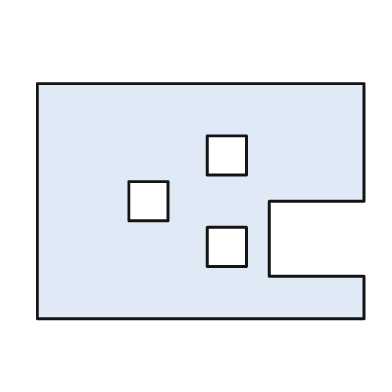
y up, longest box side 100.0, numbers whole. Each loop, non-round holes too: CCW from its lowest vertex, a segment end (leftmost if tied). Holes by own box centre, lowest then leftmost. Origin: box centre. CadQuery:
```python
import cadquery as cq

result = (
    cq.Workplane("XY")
    .moveTo(-50.0, -36.0)
    .lineTo(50.0, -36.0)
    .lineTo(50.0, -23.0)
    .lineTo(21.0, -23.0)
    .lineTo(21.0, 0.0)
    .lineTo(50.0, 0.0)
    .lineTo(50.0, 36.0)
    .lineTo(-50.0, 36.0)
    .close()
    .moveTo(2.0, -20.0)
    .lineTo(14.0, -20.0)
    .lineTo(14.0, -8.0)
    .lineTo(2.0, -8.0)
    .close()
    .moveTo(-22.0, -6.0)
    .lineTo(-10.0, -6.0)
    .lineTo(-10.0, 6.0)
    .lineTo(-22.0, 6.0)
    .close()
    .moveTo(2.0, 8.0)
    .lineTo(14.0, 8.0)
    .lineTo(14.0, 20.0)
    .lineTo(2.0, 20.0)
    .close()
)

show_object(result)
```